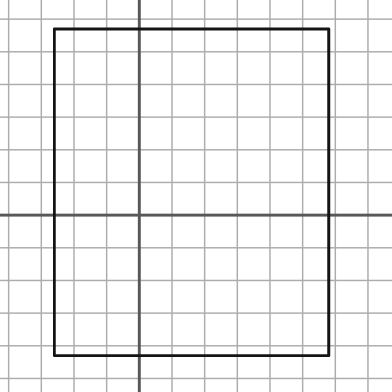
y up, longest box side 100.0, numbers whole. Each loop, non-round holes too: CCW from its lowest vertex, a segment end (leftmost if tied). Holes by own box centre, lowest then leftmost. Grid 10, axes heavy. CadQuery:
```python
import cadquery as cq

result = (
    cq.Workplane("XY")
    .moveTo(-26.0, -43.0)
    .lineTo(58.0, -43.0)
    .lineTo(58.0, 57.0)
    .lineTo(-26.0, 57.0)
    .close()
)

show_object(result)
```